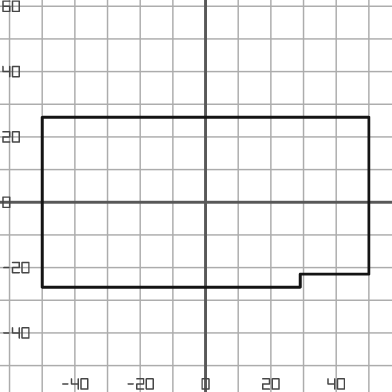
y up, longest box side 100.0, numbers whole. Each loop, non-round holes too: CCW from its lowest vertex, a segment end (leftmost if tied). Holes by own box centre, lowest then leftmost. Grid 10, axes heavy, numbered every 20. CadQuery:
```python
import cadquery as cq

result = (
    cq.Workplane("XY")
    .moveTo(-50.0, -26.0)
    .lineTo(29.0, -26.0)
    .lineTo(29.0, -22.0)
    .lineTo(50.0, -22.0)
    .lineTo(50.0, 26.0)
    .lineTo(-50.0, 26.0)
    .close()
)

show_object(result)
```